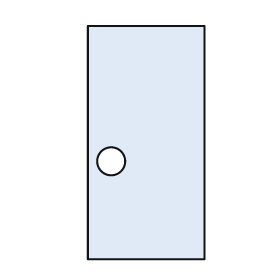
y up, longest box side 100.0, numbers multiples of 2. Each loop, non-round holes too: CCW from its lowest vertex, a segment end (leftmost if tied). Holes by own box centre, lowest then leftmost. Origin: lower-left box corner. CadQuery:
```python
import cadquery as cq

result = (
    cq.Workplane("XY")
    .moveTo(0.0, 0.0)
    .lineTo(50.0, 0.0)
    .lineTo(50.0, 100.0)
    .lineTo(0.0, 100.0)
    .close()
    .moveTo(10.0, 42.0)
    .circle(6.0)
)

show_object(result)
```